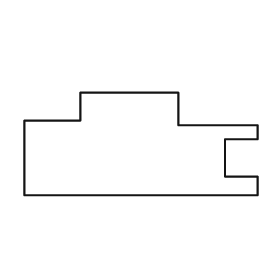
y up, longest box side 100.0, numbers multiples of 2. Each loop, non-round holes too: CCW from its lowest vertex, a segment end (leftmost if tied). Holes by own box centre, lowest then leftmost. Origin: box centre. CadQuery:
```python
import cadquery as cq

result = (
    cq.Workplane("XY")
    .moveTo(-50.0, -22.0)
    .lineTo(50.0, -22.0)
    .lineTo(50.0, -14.0)
    .lineTo(36.0, -14.0)
    .lineTo(36.0, 2.0)
    .lineTo(50.0, 2.0)
    .lineTo(50.0, 8.0)
    .lineTo(16.0, 8.0)
    .lineTo(16.0, 22.0)
    .lineTo(-26.0, 22.0)
    .lineTo(-26.0, 10.0)
    .lineTo(-50.0, 10.0)
    .close()
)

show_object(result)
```